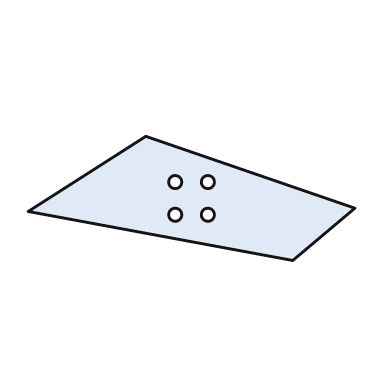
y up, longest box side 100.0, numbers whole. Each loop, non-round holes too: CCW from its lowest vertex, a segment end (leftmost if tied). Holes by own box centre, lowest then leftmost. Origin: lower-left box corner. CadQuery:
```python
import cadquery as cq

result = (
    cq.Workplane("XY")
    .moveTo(81.0, 0.0)
    .lineTo(100.0, 16.0)
    .lineTo(36.0, 38.0)
    .lineTo(0.0, 15.0)
    .close()
    .moveTo(45.0, 14.0)
    .circle(2.0)
    .moveTo(55.0, 14.0)
    .circle(2.0)
    .moveTo(45.0, 24.0)
    .circle(2.0)
    .moveTo(55.0, 24.0)
    .circle(2.0)
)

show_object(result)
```